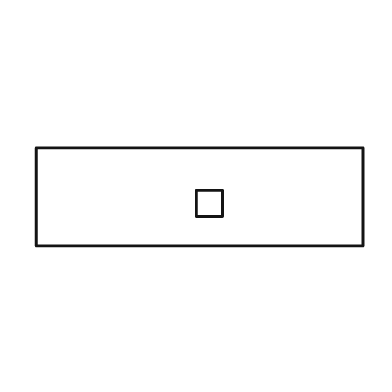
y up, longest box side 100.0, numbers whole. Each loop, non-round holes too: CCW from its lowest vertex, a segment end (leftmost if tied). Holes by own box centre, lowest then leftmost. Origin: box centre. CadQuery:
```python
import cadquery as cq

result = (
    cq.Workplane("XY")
    .moveTo(-50.0, -15.0)
    .lineTo(50.0, -15.0)
    .lineTo(50.0, 15.0)
    .lineTo(-50.0, 15.0)
    .close()
    .moveTo(-1.0, -6.0)
    .lineTo(7.0, -6.0)
    .lineTo(7.0, 2.0)
    .lineTo(-1.0, 2.0)
    .close()
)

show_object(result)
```